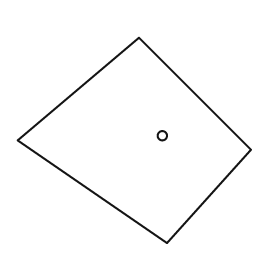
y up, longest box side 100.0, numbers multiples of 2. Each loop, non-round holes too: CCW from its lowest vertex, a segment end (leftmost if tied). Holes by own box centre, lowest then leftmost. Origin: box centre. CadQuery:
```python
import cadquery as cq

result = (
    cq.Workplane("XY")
    .moveTo(14.0, -44.0)
    .lineTo(50.0, -4.0)
    .lineTo(2.0, 44.0)
    .lineTo(-50.0, 0.0)
    .close()
    .moveTo(12.0, 2.0)
    .circle(2.0)
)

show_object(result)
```